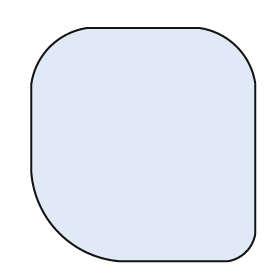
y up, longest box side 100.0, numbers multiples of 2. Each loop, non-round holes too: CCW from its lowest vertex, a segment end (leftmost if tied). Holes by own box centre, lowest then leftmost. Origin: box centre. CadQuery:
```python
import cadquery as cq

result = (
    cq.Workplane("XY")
    .moveTo(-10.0, -50.0)
    .lineTo(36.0, -50.0)
    .threePointArc((44.0, -46.0), (48.0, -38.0))
    .lineTo(48.0, 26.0)
    .threePointArc((40.0, 42.0), (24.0, 50.0))
    .lineTo(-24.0, 50.0)
    .threePointArc((-40.0, 42.0), (-48.0, 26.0))
    .lineTo(-48.0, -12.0)
    .threePointArc((-36.0, -38.0), (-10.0, -50.0))
    .close()
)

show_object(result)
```